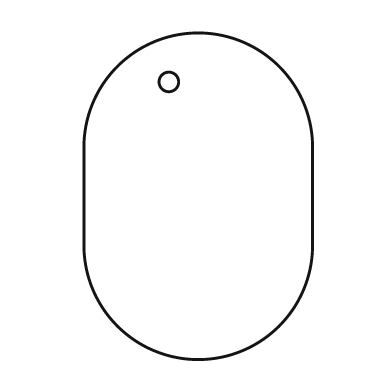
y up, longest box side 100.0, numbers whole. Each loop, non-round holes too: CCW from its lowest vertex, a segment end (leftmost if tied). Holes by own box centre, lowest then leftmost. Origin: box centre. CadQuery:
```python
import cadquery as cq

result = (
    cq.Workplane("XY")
    .moveTo(-35.0, -15.0)
    .threePointArc((0.0, -50.0), (35.0, -15.0))
    .lineTo(35.0, 15.0)
    .threePointArc((0.0, 50.0), (-35.0, 15.0))
    .close()
    .moveTo(-9.0, 35.0)
    .circle(3.0)
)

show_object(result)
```